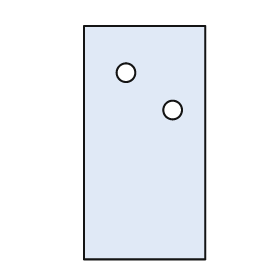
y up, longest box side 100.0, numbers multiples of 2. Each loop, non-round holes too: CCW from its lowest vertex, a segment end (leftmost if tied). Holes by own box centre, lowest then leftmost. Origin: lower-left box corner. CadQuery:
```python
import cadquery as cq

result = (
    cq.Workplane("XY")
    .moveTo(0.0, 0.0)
    .lineTo(52.0, 0.0)
    .lineTo(52.0, 100.0)
    .lineTo(0.0, 100.0)
    .close()
    .moveTo(38.0, 64.0)
    .circle(4.0)
    .moveTo(18.0, 80.0)
    .circle(4.0)
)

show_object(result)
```